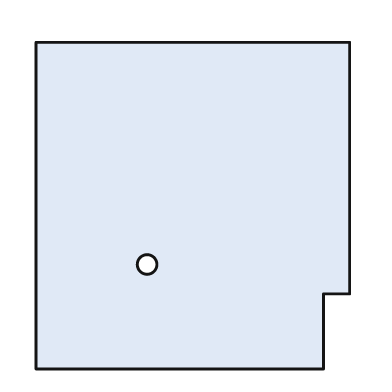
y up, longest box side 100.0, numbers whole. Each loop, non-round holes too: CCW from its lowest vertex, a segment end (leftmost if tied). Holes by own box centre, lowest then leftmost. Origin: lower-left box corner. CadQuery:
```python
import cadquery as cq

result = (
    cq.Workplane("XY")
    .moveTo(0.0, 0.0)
    .lineTo(88.0, 0.0)
    .lineTo(88.0, 23.0)
    .lineTo(96.0, 23.0)
    .lineTo(96.0, 100.0)
    .lineTo(0.0, 100.0)
    .close()
    .moveTo(34.0, 32.0)
    .circle(3.0)
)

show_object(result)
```